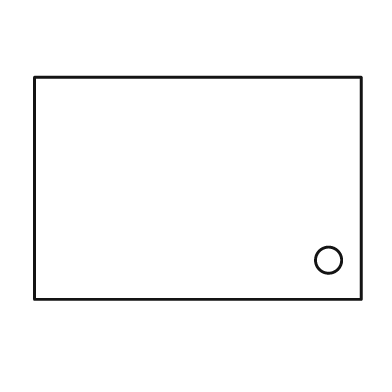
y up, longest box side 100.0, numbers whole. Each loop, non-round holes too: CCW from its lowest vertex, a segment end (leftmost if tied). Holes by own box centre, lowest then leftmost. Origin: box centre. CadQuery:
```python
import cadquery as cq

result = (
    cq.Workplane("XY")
    .moveTo(-50.0, -34.0)
    .lineTo(50.0, -34.0)
    .lineTo(50.0, 34.0)
    .lineTo(-50.0, 34.0)
    .close()
    .moveTo(40.0, -22.0)
    .circle(4.0)
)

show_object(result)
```